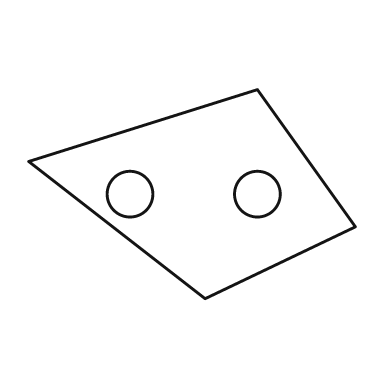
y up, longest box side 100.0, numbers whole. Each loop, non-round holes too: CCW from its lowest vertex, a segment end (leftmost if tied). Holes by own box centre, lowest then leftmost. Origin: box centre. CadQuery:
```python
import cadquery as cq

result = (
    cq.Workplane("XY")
    .moveTo(4.0, -32.0)
    .lineTo(50.0, -10.0)
    .lineTo(20.0, 32.0)
    .lineTo(-50.0, 10.0)
    .close()
    .moveTo(-19.0, 0.0)
    .circle(7.0)
    .moveTo(20.0, 0.0)
    .circle(7.0)
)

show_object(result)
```